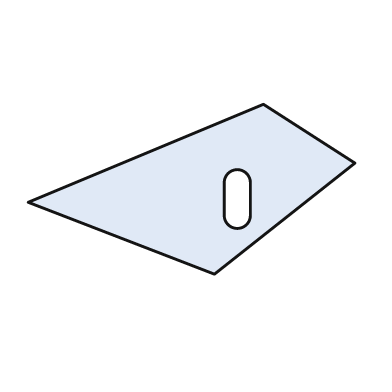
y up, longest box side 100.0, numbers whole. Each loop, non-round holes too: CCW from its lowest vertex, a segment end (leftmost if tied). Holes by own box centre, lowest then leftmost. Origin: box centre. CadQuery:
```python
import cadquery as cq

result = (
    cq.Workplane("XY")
    .moveTo(7.0, -26.0)
    .lineTo(50.0, 8.0)
    .lineTo(22.0, 26.0)
    .lineTo(-50.0, -4.0)
    .close()
    .moveTo(10.0, -8.0)
    .threePointArc((14.0, -12.0), (18.0, -8.0))
    .lineTo(18.0, 2.0)
    .threePointArc((14.0, 6.0), (10.0, 2.0))
    .close()
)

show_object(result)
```